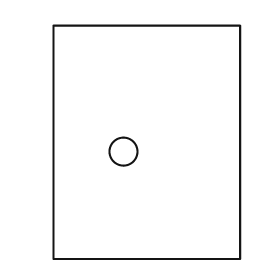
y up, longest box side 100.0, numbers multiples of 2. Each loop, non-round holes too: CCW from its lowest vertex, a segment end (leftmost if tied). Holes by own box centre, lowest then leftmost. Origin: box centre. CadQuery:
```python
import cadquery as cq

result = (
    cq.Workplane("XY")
    .moveTo(-40.0, -50.0)
    .lineTo(40.0, -50.0)
    .lineTo(40.0, 50.0)
    .lineTo(-40.0, 50.0)
    .close()
    .moveTo(-10.0, -4.0)
    .circle(6.0)
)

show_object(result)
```